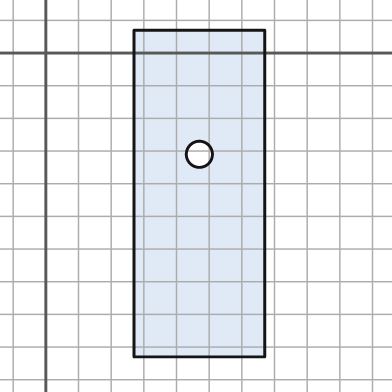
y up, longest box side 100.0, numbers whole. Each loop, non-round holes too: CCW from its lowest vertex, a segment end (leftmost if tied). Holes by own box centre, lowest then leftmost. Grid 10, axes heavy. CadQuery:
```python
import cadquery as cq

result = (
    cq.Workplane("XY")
    .moveTo(27.0, -93.0)
    .lineTo(67.0, -93.0)
    .lineTo(67.0, 7.0)
    .lineTo(27.0, 7.0)
    .close()
    .moveTo(47.0, -31.0)
    .circle(4.0)
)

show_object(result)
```